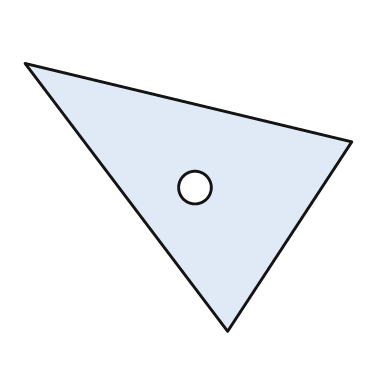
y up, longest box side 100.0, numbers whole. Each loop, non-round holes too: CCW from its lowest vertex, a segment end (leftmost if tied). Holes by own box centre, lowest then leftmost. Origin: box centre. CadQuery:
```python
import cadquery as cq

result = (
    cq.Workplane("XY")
    .moveTo(12.0, -41.0)
    .lineTo(50.0, 17.0)
    .lineTo(-50.0, 41.0)
    .close()
    .moveTo(2.0, 3.0)
    .circle(5.0)
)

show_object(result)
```